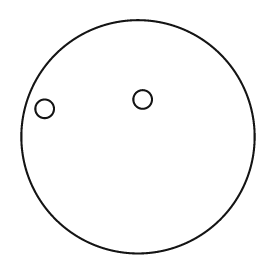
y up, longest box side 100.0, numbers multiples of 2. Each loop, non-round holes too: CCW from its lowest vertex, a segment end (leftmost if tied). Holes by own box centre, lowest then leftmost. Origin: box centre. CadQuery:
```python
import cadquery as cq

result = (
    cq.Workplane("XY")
    .moveTo(0.0, 0.0)
    .circle(50.0)
    .moveTo(-40.0, 12.0)
    .circle(4.0)
    .moveTo(2.0, 16.0)
    .circle(4.0)
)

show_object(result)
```